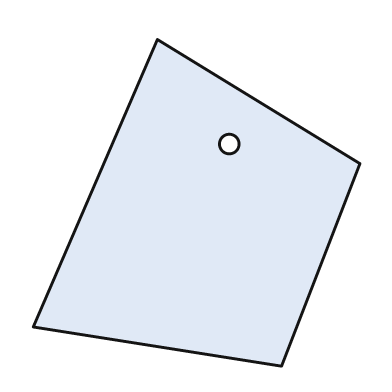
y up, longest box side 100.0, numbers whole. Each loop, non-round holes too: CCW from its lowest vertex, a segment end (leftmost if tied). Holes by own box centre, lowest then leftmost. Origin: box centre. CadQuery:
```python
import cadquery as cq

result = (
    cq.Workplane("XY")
    .moveTo(26.0, -50.0)
    .lineTo(50.0, 12.0)
    .lineTo(-12.0, 50.0)
    .lineTo(-50.0, -38.0)
    .close()
    .moveTo(10.0, 18.0)
    .circle(3.0)
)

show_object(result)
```